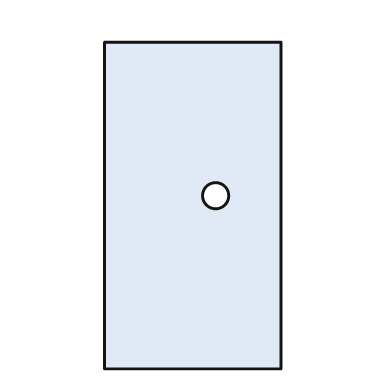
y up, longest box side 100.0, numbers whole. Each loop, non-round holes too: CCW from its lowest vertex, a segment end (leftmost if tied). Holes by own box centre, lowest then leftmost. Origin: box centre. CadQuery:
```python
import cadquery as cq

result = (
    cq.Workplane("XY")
    .moveTo(-27.0, -50.0)
    .lineTo(27.0, -50.0)
    .lineTo(27.0, 50.0)
    .lineTo(-27.0, 50.0)
    .close()
    .moveTo(7.0, 3.0)
    .circle(4.0)
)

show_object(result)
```